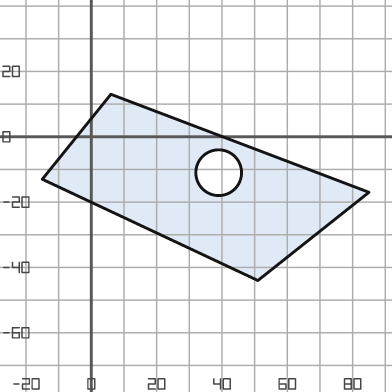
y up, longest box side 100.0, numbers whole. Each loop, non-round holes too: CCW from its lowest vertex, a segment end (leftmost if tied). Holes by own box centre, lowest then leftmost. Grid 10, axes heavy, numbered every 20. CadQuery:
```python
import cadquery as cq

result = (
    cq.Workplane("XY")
    .moveTo(51.0, -44.0)
    .lineTo(85.0, -17.0)
    .lineTo(6.0, 13.0)
    .lineTo(-15.0, -13.0)
    .close()
    .moveTo(39.0, -11.0)
    .circle(7.0)
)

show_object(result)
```